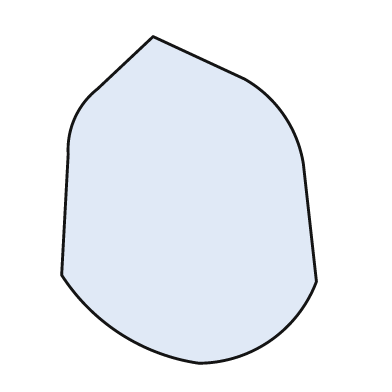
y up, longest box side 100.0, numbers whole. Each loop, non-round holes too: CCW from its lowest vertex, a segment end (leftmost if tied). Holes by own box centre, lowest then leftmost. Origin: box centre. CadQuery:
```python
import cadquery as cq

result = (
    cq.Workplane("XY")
    .moveTo(3.0, -50.0)
    .threePointArc((25.0, -43.0), (39.0, -25.0))
    .lineTo(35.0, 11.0)
    .threePointArc((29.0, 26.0), (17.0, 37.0))
    .lineTo(-11.0, 50.0)
    .lineTo(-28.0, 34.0)
    .threePointArc((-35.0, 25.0), (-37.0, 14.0))
    .lineTo(-39.0, -23.0)
    .threePointArc((-21.0, -41.0), (3.0, -50.0))
    .close()
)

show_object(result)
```